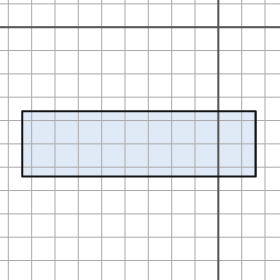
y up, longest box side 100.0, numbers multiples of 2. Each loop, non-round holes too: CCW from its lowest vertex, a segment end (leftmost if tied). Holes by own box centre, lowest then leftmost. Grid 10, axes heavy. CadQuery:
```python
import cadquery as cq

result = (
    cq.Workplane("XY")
    .moveTo(-84.0, -64.0)
    .lineTo(16.0, -64.0)
    .lineTo(16.0, -36.0)
    .lineTo(-84.0, -36.0)
    .close()
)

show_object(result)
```